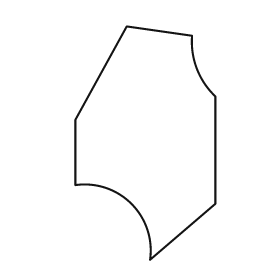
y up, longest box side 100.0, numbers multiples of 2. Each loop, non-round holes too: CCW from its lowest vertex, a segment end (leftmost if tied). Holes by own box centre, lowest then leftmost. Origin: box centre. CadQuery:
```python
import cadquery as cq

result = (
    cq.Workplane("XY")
    .moveTo(2.0, -50.0)
    .lineTo(30.0, -26.0)
    .lineTo(30.0, 20.0)
    .threePointArc((22.0, 32.0), (20.0, 46.0))
    .lineTo(-8.0, 50.0)
    .lineTo(-30.0, 10.0)
    .lineTo(-30.0, -18.0)
    .threePointArc((-6.0, -26.0), (2.0, -50.0))
    .close()
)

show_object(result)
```